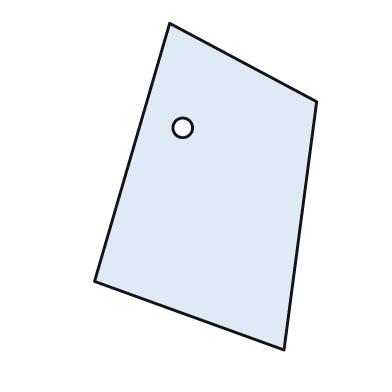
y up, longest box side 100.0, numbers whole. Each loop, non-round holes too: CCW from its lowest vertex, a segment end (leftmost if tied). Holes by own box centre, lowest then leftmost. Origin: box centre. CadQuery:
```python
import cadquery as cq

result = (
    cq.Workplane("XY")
    .moveTo(24.0, -50.0)
    .lineTo(34.0, 26.0)
    .lineTo(-11.0, 50.0)
    .lineTo(-34.0, -29.0)
    .close()
    .moveTo(-7.0, 18.0)
    .circle(3.0)
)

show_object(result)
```